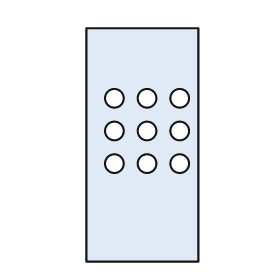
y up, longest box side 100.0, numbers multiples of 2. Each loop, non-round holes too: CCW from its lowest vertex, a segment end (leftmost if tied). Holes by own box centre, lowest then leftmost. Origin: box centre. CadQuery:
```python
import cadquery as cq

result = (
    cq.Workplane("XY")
    .moveTo(-24.0, -50.0)
    .lineTo(24.0, -50.0)
    .lineTo(24.0, 50.0)
    .lineTo(-24.0, 50.0)
    .close()
    .moveTo(-12.0, -8.0)
    .circle(4.0)
    .moveTo(2.0, -8.0)
    .circle(4.0)
    .moveTo(16.0, -8.0)
    .circle(4.0)
    .moveTo(-12.0, 6.0)
    .circle(4.0)
    .moveTo(2.0, 6.0)
    .circle(4.0)
    .moveTo(16.0, 6.0)
    .circle(4.0)
    .moveTo(-12.0, 20.0)
    .circle(4.0)
    .moveTo(2.0, 20.0)
    .circle(4.0)
    .moveTo(16.0, 20.0)
    .circle(4.0)
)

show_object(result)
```